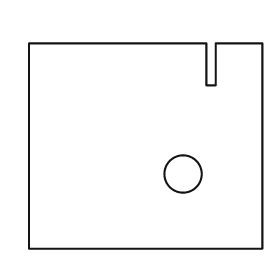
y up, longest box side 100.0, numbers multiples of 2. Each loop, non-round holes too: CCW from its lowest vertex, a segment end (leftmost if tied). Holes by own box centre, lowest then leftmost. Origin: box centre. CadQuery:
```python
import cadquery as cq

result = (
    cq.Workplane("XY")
    .moveTo(-50.0, -44.0)
    .lineTo(50.0, -44.0)
    .lineTo(50.0, 44.0)
    .lineTo(30.0, 44.0)
    .lineTo(30.0, 26.0)
    .lineTo(26.0, 26.0)
    .lineTo(26.0, 44.0)
    .lineTo(-50.0, 44.0)
    .close()
    .moveTo(16.0, -12.0)
    .circle(8.0)
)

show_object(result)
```